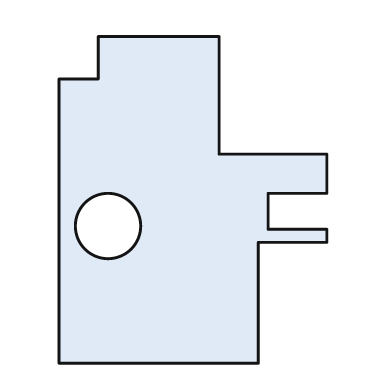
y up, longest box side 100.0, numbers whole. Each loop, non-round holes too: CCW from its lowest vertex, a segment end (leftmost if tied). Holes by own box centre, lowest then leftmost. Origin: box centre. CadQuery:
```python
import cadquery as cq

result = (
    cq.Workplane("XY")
    .moveTo(-41.0, -50.0)
    .lineTo(20.0, -50.0)
    .lineTo(20.0, -13.0)
    .lineTo(41.0, -13.0)
    .lineTo(41.0, -9.0)
    .lineTo(23.0, -9.0)
    .lineTo(23.0, 2.0)
    .lineTo(41.0, 2.0)
    .lineTo(41.0, 14.0)
    .lineTo(8.0, 14.0)
    .lineTo(8.0, 50.0)
    .lineTo(-29.0, 50.0)
    .lineTo(-29.0, 37.0)
    .lineTo(-41.0, 37.0)
    .close()
    .moveTo(-26.0, -8.0)
    .circle(10.0)
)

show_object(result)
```